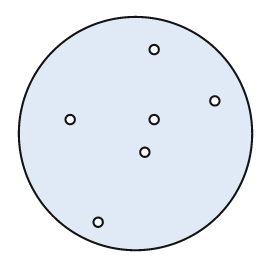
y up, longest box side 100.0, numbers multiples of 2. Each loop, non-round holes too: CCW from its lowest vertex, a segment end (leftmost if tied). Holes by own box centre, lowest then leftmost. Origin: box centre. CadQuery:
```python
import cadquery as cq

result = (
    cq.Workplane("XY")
    .moveTo(0.0, 0.0)
    .circle(50.0)
    .moveTo(-16.0, -38.0)
    .circle(2.0)
    .moveTo(4.0, -8.0)
    .circle(2.0)
    .moveTo(-28.0, 6.0)
    .circle(2.0)
    .moveTo(8.0, 6.0)
    .circle(2.0)
    .moveTo(34.0, 14.0)
    .circle(2.0)
    .moveTo(8.0, 36.0)
    .circle(2.0)
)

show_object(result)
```